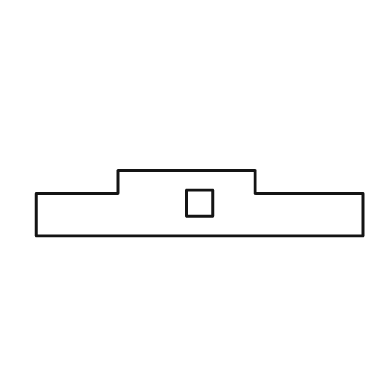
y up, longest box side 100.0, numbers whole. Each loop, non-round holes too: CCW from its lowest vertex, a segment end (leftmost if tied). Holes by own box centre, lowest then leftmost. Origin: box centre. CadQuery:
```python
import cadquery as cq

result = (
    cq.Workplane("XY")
    .moveTo(-50.0, -10.0)
    .lineTo(50.0, -10.0)
    .lineTo(50.0, 3.0)
    .lineTo(17.0, 3.0)
    .lineTo(17.0, 10.0)
    .lineTo(-25.0, 10.0)
    .lineTo(-25.0, 3.0)
    .lineTo(-50.0, 3.0)
    .close()
    .moveTo(-4.0, -4.0)
    .lineTo(4.0, -4.0)
    .lineTo(4.0, 4.0)
    .lineTo(-4.0, 4.0)
    .close()
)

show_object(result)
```